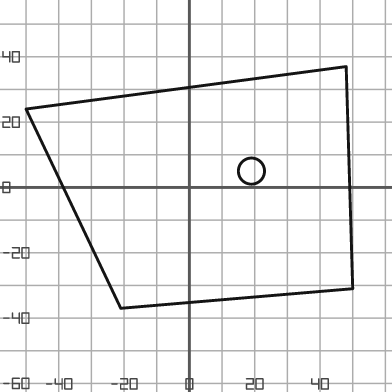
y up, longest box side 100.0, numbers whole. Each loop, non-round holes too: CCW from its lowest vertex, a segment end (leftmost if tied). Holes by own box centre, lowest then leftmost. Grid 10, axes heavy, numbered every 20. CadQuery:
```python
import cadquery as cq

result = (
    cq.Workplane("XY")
    .moveTo(-21.0, -37.0)
    .lineTo(50.0, -31.0)
    .lineTo(48.0, 37.0)
    .lineTo(-50.0, 24.0)
    .close()
    .moveTo(19.0, 5.0)
    .circle(4.0)
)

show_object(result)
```